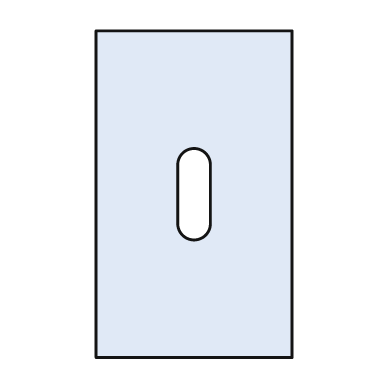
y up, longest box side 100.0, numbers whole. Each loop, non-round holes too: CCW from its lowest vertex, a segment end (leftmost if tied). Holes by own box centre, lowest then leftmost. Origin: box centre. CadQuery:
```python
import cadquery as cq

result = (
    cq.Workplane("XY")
    .moveTo(-30.0, -50.0)
    .lineTo(30.0, -50.0)
    .lineTo(30.0, 50.0)
    .lineTo(-30.0, 50.0)
    .close()
    .moveTo(-5.0, -9.0)
    .threePointArc((0.0, -14.0), (5.0, -9.0))
    .lineTo(5.0, 9.0)
    .threePointArc((0.0, 14.0), (-5.0, 9.0))
    .close()
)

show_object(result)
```